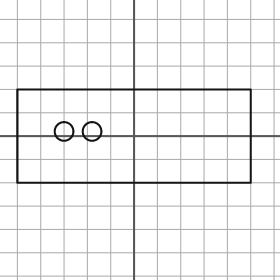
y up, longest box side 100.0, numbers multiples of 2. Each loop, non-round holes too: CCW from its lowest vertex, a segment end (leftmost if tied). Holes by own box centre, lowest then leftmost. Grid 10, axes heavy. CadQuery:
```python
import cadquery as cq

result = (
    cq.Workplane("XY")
    .moveTo(-50.0, -20.0)
    .lineTo(50.0, -20.0)
    .lineTo(50.0, 20.0)
    .lineTo(-50.0, 20.0)
    .close()
    .moveTo(-30.0, 2.0)
    .circle(4.0)
    .moveTo(-18.0, 2.0)
    .circle(4.0)
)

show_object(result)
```